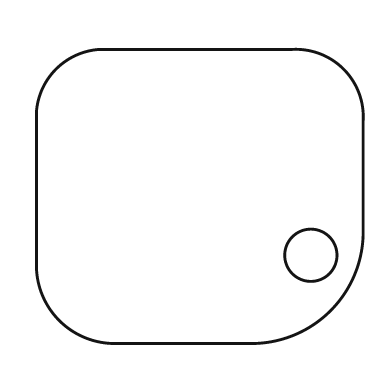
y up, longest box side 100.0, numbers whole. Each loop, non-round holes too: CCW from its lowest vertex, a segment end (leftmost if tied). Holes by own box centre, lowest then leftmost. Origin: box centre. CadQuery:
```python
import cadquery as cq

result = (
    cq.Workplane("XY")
    .moveTo(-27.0, -45.0)
    .lineTo(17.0, -45.0)
    .threePointArc((40.0, -35.0), (50.0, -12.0))
    .lineTo(50.0, 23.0)
    .threePointArc((44.0, 39.0), (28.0, 45.0))
    .lineTo(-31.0, 45.0)
    .threePointArc((-44.0, 39.0), (-50.0, 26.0))
    .lineTo(-50.0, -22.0)
    .threePointArc((-43.0, -38.0), (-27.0, -45.0))
    .close()
    .moveTo(34.0, -18.0)
    .circle(8.0)
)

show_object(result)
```